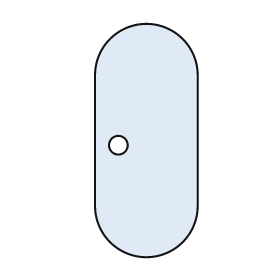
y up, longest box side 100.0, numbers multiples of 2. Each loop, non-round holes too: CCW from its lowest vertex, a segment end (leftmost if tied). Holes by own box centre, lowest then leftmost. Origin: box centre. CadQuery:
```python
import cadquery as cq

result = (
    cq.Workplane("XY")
    .moveTo(-22.0, -28.0)
    .threePointArc((0.0, -50.0), (22.0, -28.0))
    .lineTo(22.0, 28.0)
    .threePointArc((0.0, 50.0), (-22.0, 28.0))
    .close()
    .moveTo(-12.0, -2.0)
    .circle(4.0)
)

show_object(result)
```